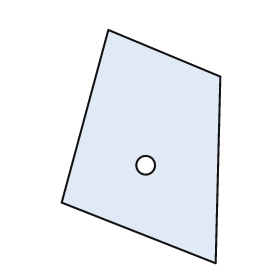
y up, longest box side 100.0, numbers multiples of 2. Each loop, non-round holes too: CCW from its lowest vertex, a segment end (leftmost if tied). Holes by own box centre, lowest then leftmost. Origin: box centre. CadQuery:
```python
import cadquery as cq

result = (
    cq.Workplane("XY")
    .moveTo(32.0, -50.0)
    .lineTo(34.0, 30.0)
    .lineTo(-14.0, 50.0)
    .lineTo(-34.0, -24.0)
    .close()
    .moveTo(2.0, -8.0)
    .circle(4.0)
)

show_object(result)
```